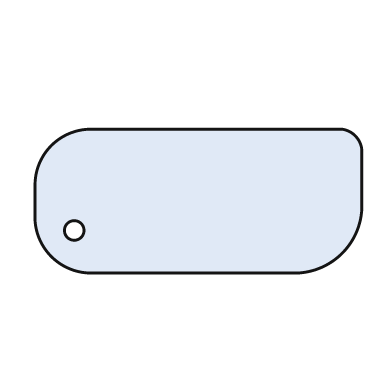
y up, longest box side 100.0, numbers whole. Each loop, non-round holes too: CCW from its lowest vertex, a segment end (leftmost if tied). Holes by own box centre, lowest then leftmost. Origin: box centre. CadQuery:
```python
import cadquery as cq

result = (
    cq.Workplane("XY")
    .moveTo(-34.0, -22.0)
    .lineTo(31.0, -22.0)
    .threePointArc((44.0, -16.0), (50.0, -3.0))
    .lineTo(50.0, 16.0)
    .threePointArc((48.0, 20.0), (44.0, 22.0))
    .lineTo(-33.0, 22.0)
    .threePointArc((-45.0, 17.0), (-50.0, 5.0))
    .lineTo(-50.0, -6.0)
    .threePointArc((-45.0, -17.0), (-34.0, -22.0))
    .close()
    .moveTo(-38.0, -9.0)
    .circle(3.0)
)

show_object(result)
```